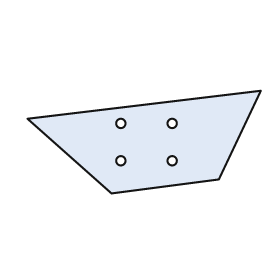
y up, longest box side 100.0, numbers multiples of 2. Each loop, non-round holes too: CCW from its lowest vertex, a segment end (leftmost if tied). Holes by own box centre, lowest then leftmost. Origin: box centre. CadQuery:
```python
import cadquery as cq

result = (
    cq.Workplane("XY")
    .moveTo(-14.0, -22.0)
    .lineTo(32.0, -16.0)
    .lineTo(50.0, 22.0)
    .lineTo(-50.0, 10.0)
    .close()
    .moveTo(-10.0, -8.0)
    .circle(2.0)
    .moveTo(12.0, -8.0)
    .circle(2.0)
    .moveTo(-10.0, 8.0)
    .circle(2.0)
    .moveTo(12.0, 8.0)
    .circle(2.0)
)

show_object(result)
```